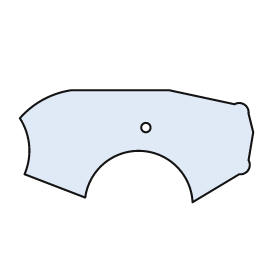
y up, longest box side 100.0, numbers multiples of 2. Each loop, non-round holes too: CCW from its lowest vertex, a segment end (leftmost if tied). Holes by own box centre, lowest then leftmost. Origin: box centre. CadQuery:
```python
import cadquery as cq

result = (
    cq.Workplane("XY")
    .moveTo(24.0, -24.0)
    .lineTo(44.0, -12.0)
    .threePointArc((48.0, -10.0), (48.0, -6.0))
    .lineTo(50.0, 6.0)
    .lineTo(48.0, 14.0)
    .threePointArc((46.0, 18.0), (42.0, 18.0))
    .lineTo(14.0, 24.0)
    .lineTo(-28.0, 24.0)
    .threePointArc((-40.0, 20.0), (-50.0, 12.0))
    .threePointArc((-46.0, 0.0), (-48.0, -12.0))
    .lineTo(-22.0, -22.0)
    .threePointArc((2.0, -2.0), (24.0, -24.0))
    .close()
    .moveTo(4.0, 8.0)
    .circle(2.0)
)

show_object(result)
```